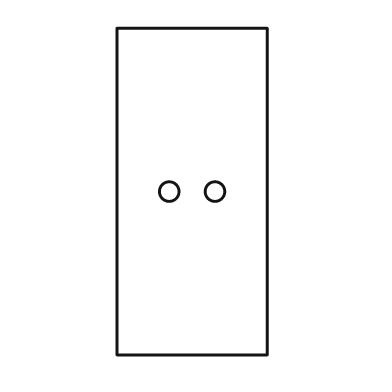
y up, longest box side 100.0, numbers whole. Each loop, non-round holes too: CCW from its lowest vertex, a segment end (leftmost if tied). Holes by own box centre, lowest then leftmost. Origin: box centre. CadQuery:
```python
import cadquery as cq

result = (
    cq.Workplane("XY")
    .moveTo(-23.0, -50.0)
    .lineTo(23.0, -50.0)
    .lineTo(23.0, 50.0)
    .lineTo(-23.0, 50.0)
    .close()
    .moveTo(-7.0, 0.0)
    .circle(3.0)
    .moveTo(7.0, 0.0)
    .circle(3.0)
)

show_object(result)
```